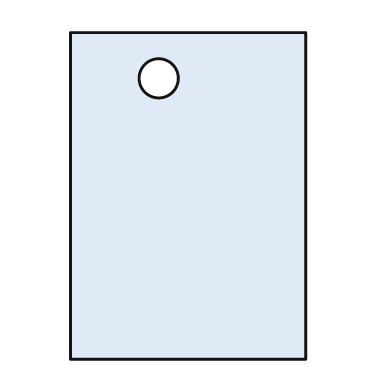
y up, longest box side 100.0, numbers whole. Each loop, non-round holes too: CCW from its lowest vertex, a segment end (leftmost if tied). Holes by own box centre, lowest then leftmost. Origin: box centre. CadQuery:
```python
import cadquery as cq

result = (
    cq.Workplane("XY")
    .moveTo(-36.0, -50.0)
    .lineTo(36.0, -50.0)
    .lineTo(36.0, 50.0)
    .lineTo(-36.0, 50.0)
    .close()
    .moveTo(-9.0, 36.0)
    .circle(6.0)
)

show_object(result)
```